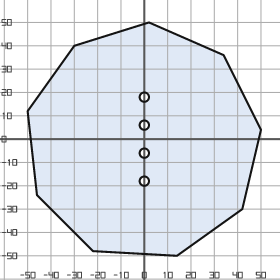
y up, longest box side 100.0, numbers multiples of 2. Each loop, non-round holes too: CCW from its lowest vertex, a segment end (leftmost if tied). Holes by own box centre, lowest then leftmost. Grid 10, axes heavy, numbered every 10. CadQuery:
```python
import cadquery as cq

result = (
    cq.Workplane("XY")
    .moveTo(14.0, -50.0)
    .lineTo(42.0, -30.0)
    .lineTo(50.0, 4.0)
    .lineTo(34.0, 36.0)
    .lineTo(2.0, 50.0)
    .lineTo(-30.0, 40.0)
    .lineTo(-50.0, 12.0)
    .lineTo(-46.0, -24.0)
    .lineTo(-22.0, -48.0)
    .close()
    .moveTo(0.0, -18.0)
    .circle(2.0)
    .moveTo(0.0, -6.0)
    .circle(2.0)
    .moveTo(0.0, 6.0)
    .circle(2.0)
    .moveTo(0.0, 18.0)
    .circle(2.0)
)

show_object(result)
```